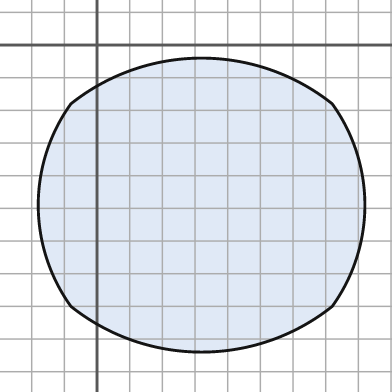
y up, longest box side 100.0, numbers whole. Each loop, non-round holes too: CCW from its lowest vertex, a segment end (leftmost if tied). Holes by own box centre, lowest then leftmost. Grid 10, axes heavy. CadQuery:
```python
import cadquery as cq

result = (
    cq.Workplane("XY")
    .moveTo(-8.0, -80.0)
    .threePointArc((32.0, -94.0), (72.0, -80.0))
    .threePointArc((82.0, -49.0), (72.0, -18.0))
    .threePointArc((32.0, -4.0), (-8.0, -18.0))
    .threePointArc((-18.0, -49.0), (-8.0, -80.0))
    .close()
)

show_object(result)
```